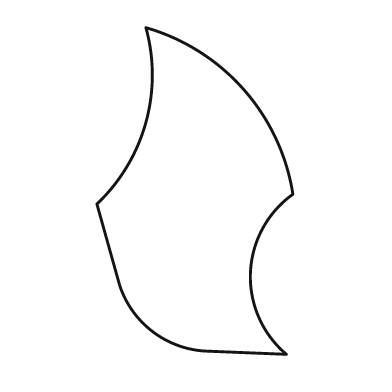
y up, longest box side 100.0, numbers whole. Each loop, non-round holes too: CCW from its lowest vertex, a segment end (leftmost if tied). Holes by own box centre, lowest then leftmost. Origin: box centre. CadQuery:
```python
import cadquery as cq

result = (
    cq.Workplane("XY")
    .moveTo(28.0, -50.0)
    .threePointArc((17.0, -25.0), (30.0, -1.0))
    .threePointArc((15.0, 31.0), (-15.0, 50.0))
    .threePointArc((-15.0, 21.0), (-30.0, -4.0))
    .lineTo(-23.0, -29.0)
    .threePointArc((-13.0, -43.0), (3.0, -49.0))
    .close()
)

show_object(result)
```